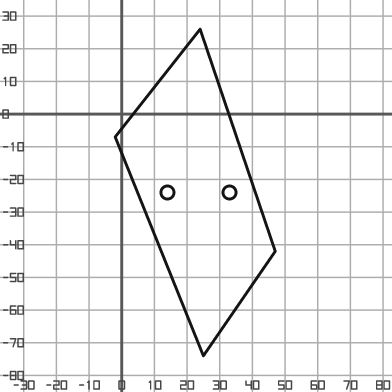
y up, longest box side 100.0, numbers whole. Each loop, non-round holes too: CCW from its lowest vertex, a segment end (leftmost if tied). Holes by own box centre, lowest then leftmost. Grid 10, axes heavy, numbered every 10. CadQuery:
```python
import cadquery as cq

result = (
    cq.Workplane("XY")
    .moveTo(25.0, -74.0)
    .lineTo(47.0, -42.0)
    .lineTo(24.0, 26.0)
    .lineTo(-2.0, -7.0)
    .close()
    .moveTo(14.0, -24.0)
    .circle(2.0)
    .moveTo(33.0, -24.0)
    .circle(2.0)
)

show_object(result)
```